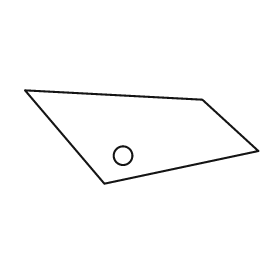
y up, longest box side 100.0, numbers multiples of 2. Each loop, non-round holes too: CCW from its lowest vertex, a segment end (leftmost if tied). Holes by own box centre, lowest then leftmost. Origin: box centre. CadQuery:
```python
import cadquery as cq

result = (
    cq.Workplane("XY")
    .moveTo(-16.0, -20.0)
    .lineTo(50.0, -6.0)
    .lineTo(26.0, 16.0)
    .lineTo(-50.0, 20.0)
    .close()
    .moveTo(-8.0, -8.0)
    .circle(4.0)
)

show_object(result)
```